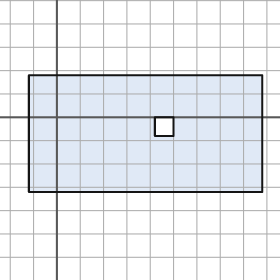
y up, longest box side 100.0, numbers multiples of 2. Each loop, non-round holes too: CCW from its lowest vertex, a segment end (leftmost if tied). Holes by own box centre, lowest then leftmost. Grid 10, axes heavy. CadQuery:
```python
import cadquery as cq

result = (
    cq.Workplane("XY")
    .moveTo(-12.0, -32.0)
    .lineTo(88.0, -32.0)
    .lineTo(88.0, 18.0)
    .lineTo(-12.0, 18.0)
    .close()
    .moveTo(42.0, -8.0)
    .lineTo(50.0, -8.0)
    .lineTo(50.0, 0.0)
    .lineTo(42.0, 0.0)
    .close()
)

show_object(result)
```